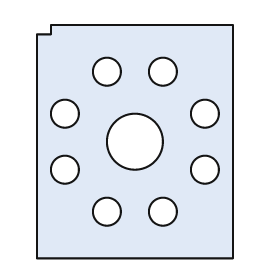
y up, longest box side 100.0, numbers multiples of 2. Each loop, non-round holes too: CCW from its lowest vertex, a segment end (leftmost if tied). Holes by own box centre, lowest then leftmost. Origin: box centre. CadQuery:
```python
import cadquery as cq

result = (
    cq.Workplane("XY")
    .moveTo(-42.0, -50.0)
    .lineTo(42.0, -50.0)
    .lineTo(42.0, 50.0)
    .lineTo(-36.0, 50.0)
    .lineTo(-36.0, 46.0)
    .lineTo(-42.0, 46.0)
    .close()
    .moveTo(-12.0, -30.0)
    .circle(6.0)
    .moveTo(12.0, -30.0)
    .circle(6.0)
    .moveTo(-30.0, -12.0)
    .circle(6.0)
    .moveTo(30.0, -12.0)
    .circle(6.0)
    .moveTo(0.0, 0.0)
    .circle(12.0)
    .moveTo(-30.0, 12.0)
    .circle(6.0)
    .moveTo(30.0, 12.0)
    .circle(6.0)
    .moveTo(-12.0, 30.0)
    .circle(6.0)
    .moveTo(12.0, 30.0)
    .circle(6.0)
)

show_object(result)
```